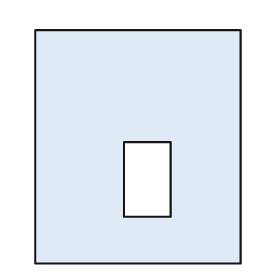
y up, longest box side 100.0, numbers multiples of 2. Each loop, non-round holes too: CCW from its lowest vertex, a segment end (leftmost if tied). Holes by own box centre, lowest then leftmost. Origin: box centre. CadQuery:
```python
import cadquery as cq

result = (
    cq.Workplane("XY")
    .moveTo(-44.0, -50.0)
    .lineTo(44.0, -50.0)
    .lineTo(44.0, 50.0)
    .lineTo(-44.0, 50.0)
    .close()
    .moveTo(-6.0, -30.0)
    .lineTo(14.0, -30.0)
    .lineTo(14.0, 2.0)
    .lineTo(-6.0, 2.0)
    .close()
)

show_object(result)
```